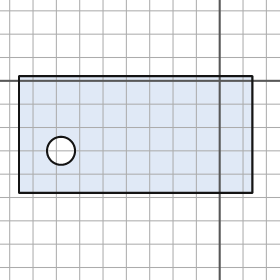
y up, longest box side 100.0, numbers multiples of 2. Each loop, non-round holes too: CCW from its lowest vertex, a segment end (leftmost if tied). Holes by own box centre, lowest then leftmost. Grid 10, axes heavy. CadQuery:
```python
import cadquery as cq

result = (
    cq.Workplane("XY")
    .moveTo(-86.0, -48.0)
    .lineTo(14.0, -48.0)
    .lineTo(14.0, 2.0)
    .lineTo(-86.0, 2.0)
    .close()
    .moveTo(-68.0, -30.0)
    .circle(6.0)
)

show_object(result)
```